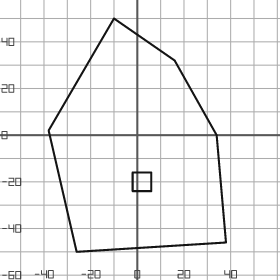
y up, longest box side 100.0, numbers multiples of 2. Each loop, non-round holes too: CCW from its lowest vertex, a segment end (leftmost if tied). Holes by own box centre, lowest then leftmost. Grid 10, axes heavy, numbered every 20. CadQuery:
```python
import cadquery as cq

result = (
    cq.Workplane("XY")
    .moveTo(-26.0, -50.0)
    .lineTo(38.0, -46.0)
    .lineTo(34.0, 0.0)
    .lineTo(16.0, 32.0)
    .lineTo(-10.0, 50.0)
    .lineTo(-38.0, 2.0)
    .close()
    .moveTo(-2.0, -24.0)
    .lineTo(6.0, -24.0)
    .lineTo(6.0, -16.0)
    .lineTo(-2.0, -16.0)
    .close()
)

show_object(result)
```